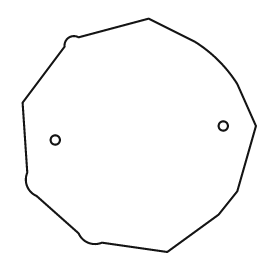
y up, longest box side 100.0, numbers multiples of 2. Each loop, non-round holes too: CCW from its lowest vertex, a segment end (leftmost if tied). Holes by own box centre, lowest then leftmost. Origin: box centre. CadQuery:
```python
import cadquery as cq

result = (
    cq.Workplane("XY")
    .moveTo(12.0, -50.0)
    .lineTo(34.0, -34.0)
    .lineTo(42.0, -24.0)
    .lineTo(50.0, 4.0)
    .lineTo(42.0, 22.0)
    .threePointArc((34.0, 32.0), (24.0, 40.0))
    .lineTo(4.0, 50.0)
    .lineTo(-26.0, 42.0)
    .threePointArc((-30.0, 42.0), (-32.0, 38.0))
    .lineTo(-50.0, 14.0)
    .lineTo(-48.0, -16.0)
    .threePointArc((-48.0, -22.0), (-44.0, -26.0))
    .lineTo(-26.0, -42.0)
    .threePointArc((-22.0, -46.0), (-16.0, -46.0))
    .close()
    .moveTo(-36.0, -2.0)
    .circle(2.0)
    .moveTo(36.0, 4.0)
    .circle(2.0)
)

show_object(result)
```